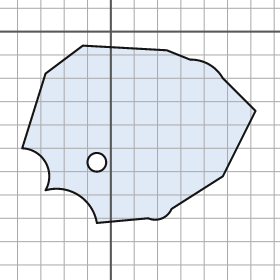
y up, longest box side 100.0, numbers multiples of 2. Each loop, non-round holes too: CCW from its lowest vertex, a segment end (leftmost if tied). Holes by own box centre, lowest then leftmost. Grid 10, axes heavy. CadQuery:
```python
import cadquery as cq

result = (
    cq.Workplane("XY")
    .moveTo(-6.0, -82.0)
    .lineTo(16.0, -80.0)
    .threePointArc((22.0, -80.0), (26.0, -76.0))
    .lineTo(48.0, -62.0)
    .lineTo(62.0, -34.0)
    .lineTo(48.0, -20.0)
    .threePointArc((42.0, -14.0), (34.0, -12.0))
    .lineTo(24.0, -8.0)
    .lineTo(-12.0, -6.0)
    .lineTo(-28.0, -18.0)
    .lineTo(-38.0, -50.0)
    .threePointArc((-28.0, -56.0), (-28.0, -68.0))
    .threePointArc((-14.0, -70.0), (-6.0, -82.0))
    .close()
    .moveTo(-6.0, -56.0)
    .circle(4.0)
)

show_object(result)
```